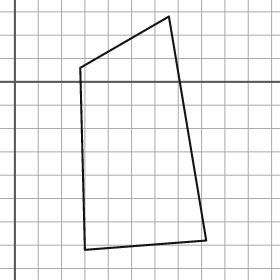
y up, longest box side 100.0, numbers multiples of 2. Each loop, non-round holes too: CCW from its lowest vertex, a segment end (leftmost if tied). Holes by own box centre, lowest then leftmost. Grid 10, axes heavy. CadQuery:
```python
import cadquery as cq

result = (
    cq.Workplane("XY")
    .moveTo(30.0, -72.0)
    .lineTo(82.0, -68.0)
    .lineTo(66.0, 28.0)
    .lineTo(28.0, 6.0)
    .close()
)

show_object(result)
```